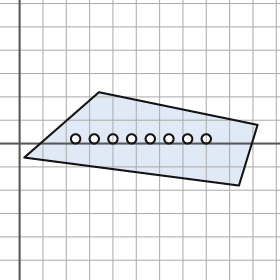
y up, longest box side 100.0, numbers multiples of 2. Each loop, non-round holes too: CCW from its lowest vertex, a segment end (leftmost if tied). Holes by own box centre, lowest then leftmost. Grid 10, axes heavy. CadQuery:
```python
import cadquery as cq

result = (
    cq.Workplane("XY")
    .moveTo(94.0, -18.0)
    .lineTo(102.0, 8.0)
    .lineTo(34.0, 22.0)
    .lineTo(2.0, -6.0)
    .close()
    .moveTo(24.0, 2.0)
    .circle(2.0)
    .moveTo(32.0, 2.0)
    .circle(2.0)
    .moveTo(40.0, 2.0)
    .circle(2.0)
    .moveTo(48.0, 2.0)
    .circle(2.0)
    .moveTo(56.0, 2.0)
    .circle(2.0)
    .moveTo(64.0, 2.0)
    .circle(2.0)
    .moveTo(72.0, 2.0)
    .circle(2.0)
    .moveTo(80.0, 2.0)
    .circle(2.0)
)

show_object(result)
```